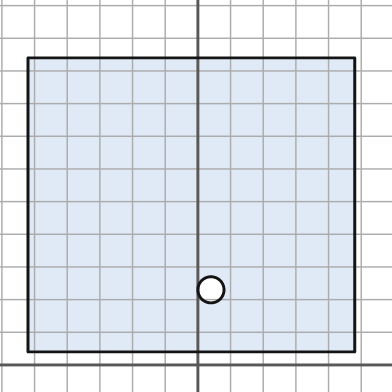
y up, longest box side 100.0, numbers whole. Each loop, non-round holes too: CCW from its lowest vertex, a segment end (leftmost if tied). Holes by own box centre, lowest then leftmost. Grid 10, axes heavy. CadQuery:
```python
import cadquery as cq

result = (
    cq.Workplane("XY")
    .moveTo(-52.0, 4.0)
    .lineTo(48.0, 4.0)
    .lineTo(48.0, 94.0)
    .lineTo(-52.0, 94.0)
    .close()
    .moveTo(4.0, 23.0)
    .circle(4.0)
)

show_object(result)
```